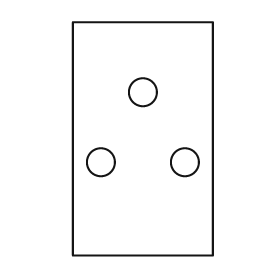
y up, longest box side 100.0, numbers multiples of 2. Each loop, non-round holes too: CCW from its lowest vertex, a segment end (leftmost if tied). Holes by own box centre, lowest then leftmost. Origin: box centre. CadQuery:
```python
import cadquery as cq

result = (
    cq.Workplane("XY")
    .moveTo(-30.0, -50.0)
    .lineTo(30.0, -50.0)
    .lineTo(30.0, 50.0)
    .lineTo(-30.0, 50.0)
    .close()
    .moveTo(-18.0, -10.0)
    .circle(6.0)
    .moveTo(18.0, -10.0)
    .circle(6.0)
    .moveTo(0.0, 20.0)
    .circle(6.0)
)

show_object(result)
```